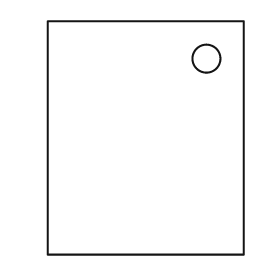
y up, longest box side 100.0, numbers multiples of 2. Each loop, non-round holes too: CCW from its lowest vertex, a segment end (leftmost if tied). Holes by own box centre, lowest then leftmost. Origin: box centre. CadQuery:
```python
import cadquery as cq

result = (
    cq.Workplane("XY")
    .moveTo(-42.0, -50.0)
    .lineTo(42.0, -50.0)
    .lineTo(42.0, 50.0)
    .lineTo(-42.0, 50.0)
    .close()
    .moveTo(26.0, 34.0)
    .circle(6.0)
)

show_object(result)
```